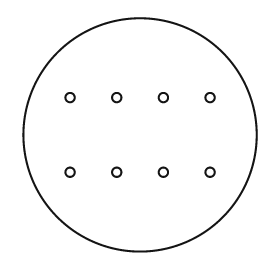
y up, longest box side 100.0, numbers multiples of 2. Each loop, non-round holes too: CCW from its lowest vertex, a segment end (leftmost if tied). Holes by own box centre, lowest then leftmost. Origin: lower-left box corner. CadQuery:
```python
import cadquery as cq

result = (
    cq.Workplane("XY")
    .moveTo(50.0, 50.0)
    .circle(50.0)
    .moveTo(20.0, 34.0)
    .circle(2.0)
    .moveTo(40.0, 34.0)
    .circle(2.0)
    .moveTo(60.0, 34.0)
    .circle(2.0)
    .moveTo(80.0, 34.0)
    .circle(2.0)
    .moveTo(20.0, 66.0)
    .circle(2.0)
    .moveTo(40.0, 66.0)
    .circle(2.0)
    .moveTo(60.0, 66.0)
    .circle(2.0)
    .moveTo(80.0, 66.0)
    .circle(2.0)
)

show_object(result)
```